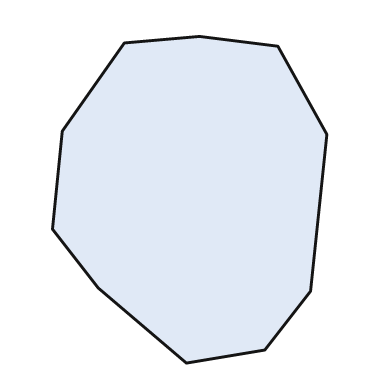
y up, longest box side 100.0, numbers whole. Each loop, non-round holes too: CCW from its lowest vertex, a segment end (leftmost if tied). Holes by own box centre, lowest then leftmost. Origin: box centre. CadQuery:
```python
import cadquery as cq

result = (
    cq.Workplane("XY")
    .moveTo(-1.0, -50.0)
    .lineTo(23.0, -46.0)
    .lineTo(37.0, -28.0)
    .lineTo(42.0, 20.0)
    .lineTo(27.0, 47.0)
    .lineTo(3.0, 50.0)
    .lineTo(-20.0, 48.0)
    .lineTo(-39.0, 21.0)
    .lineTo(-42.0, -9.0)
    .lineTo(-28.0, -27.0)
    .close()
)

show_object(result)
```